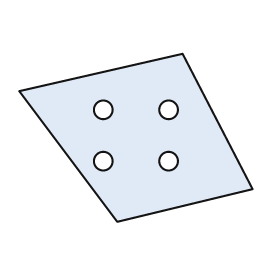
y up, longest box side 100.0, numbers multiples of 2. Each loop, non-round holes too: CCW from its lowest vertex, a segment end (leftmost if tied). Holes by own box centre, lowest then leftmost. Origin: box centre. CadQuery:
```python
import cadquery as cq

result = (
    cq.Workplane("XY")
    .moveTo(-8.0, -36.0)
    .lineTo(50.0, -22.0)
    .lineTo(20.0, 36.0)
    .lineTo(-50.0, 20.0)
    .close()
    .moveTo(-14.0, -10.0)
    .circle(4.0)
    .moveTo(14.0, -10.0)
    .circle(4.0)
    .moveTo(-14.0, 12.0)
    .circle(4.0)
    .moveTo(14.0, 12.0)
    .circle(4.0)
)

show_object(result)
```